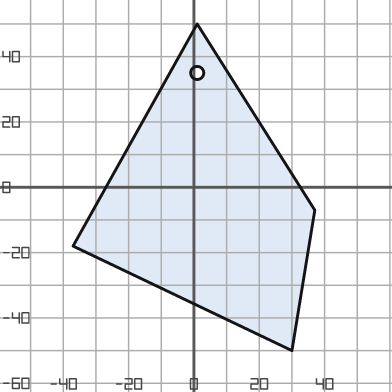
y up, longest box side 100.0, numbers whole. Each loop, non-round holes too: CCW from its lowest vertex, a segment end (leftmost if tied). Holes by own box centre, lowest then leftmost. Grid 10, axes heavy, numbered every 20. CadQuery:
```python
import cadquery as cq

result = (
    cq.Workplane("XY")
    .moveTo(30.0, -50.0)
    .lineTo(37.0, -7.0)
    .lineTo(1.0, 50.0)
    .lineTo(-37.0, -18.0)
    .close()
    .moveTo(1.0, 35.0)
    .circle(2.0)
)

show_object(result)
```